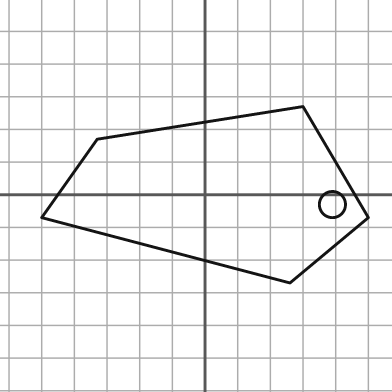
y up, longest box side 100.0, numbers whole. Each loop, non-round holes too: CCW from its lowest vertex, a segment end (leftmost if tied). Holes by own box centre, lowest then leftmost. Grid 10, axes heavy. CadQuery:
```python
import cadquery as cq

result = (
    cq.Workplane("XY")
    .moveTo(26.0, -27.0)
    .lineTo(50.0, -7.0)
    .lineTo(30.0, 27.0)
    .lineTo(-33.0, 17.0)
    .lineTo(-50.0, -7.0)
    .close()
    .moveTo(39.0, -3.0)
    .circle(4.0)
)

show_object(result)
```